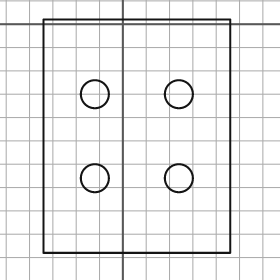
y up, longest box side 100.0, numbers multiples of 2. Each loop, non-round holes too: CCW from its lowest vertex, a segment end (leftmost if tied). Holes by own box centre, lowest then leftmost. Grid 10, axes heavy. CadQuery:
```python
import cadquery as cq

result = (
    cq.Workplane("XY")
    .moveTo(-34.0, -98.0)
    .lineTo(46.0, -98.0)
    .lineTo(46.0, 2.0)
    .lineTo(-34.0, 2.0)
    .close()
    .moveTo(-12.0, -66.0)
    .circle(6.0)
    .moveTo(24.0, -66.0)
    .circle(6.0)
    .moveTo(-12.0, -30.0)
    .circle(6.0)
    .moveTo(24.0, -30.0)
    .circle(6.0)
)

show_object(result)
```